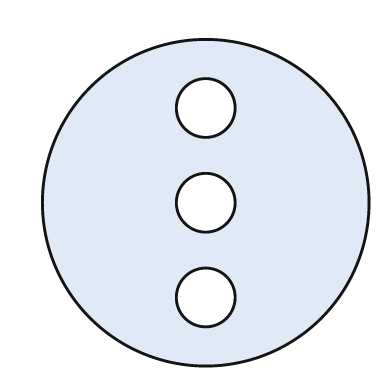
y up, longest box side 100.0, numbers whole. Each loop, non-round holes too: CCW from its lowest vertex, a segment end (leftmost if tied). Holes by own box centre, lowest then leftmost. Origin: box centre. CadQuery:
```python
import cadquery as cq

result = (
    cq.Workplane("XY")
    .moveTo(0.0, 0.0)
    .circle(50.0)
    .moveTo(0.0, -29.0)
    .circle(9.0)
    .moveTo(0.0, 0.0)
    .circle(9.0)
    .moveTo(0.0, 29.0)
    .circle(9.0)
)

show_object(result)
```